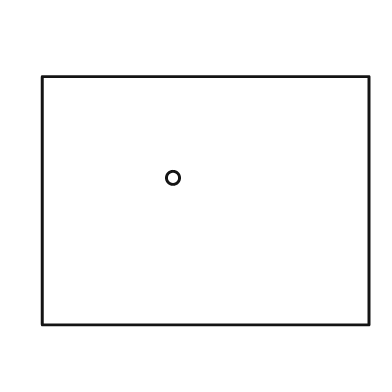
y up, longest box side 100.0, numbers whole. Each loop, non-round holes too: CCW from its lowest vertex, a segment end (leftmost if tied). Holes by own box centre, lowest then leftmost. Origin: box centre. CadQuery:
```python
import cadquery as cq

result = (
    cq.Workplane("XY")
    .moveTo(-50.0, -38.0)
    .lineTo(50.0, -38.0)
    .lineTo(50.0, 38.0)
    .lineTo(-50.0, 38.0)
    .close()
    .moveTo(-10.0, 7.0)
    .circle(2.0)
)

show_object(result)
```